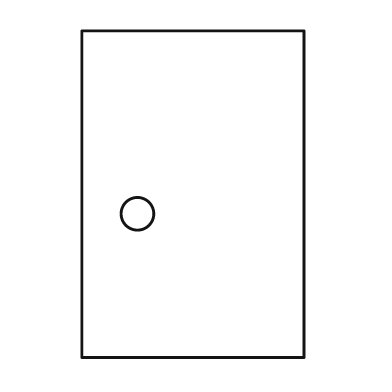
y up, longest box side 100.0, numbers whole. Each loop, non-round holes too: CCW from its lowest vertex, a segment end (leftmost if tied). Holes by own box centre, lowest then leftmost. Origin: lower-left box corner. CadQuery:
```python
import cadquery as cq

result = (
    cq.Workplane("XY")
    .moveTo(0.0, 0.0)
    .lineTo(68.0, 0.0)
    .lineTo(68.0, 100.0)
    .lineTo(0.0, 100.0)
    .close()
    .moveTo(17.0, 44.0)
    .circle(5.0)
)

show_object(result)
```